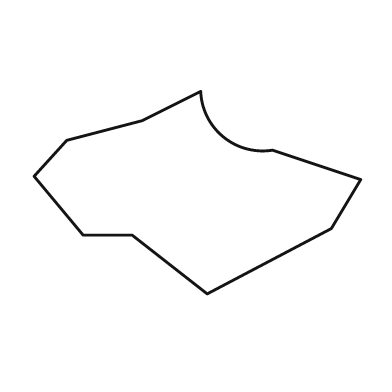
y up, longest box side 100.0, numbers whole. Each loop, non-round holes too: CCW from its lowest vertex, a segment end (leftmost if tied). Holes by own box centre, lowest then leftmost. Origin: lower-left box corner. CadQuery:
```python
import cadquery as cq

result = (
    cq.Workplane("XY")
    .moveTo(53.0, 0.0)
    .lineTo(91.0, 20.0)
    .lineTo(100.0, 35.0)
    .lineTo(73.0, 44.0)
    .threePointArc((58.0, 48.0), (51.0, 62.0))
    .lineTo(33.0, 53.0)
    .lineTo(10.0, 47.0)
    .lineTo(0.0, 36.0)
    .lineTo(15.0, 18.0)
    .lineTo(30.0, 18.0)
    .close()
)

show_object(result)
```